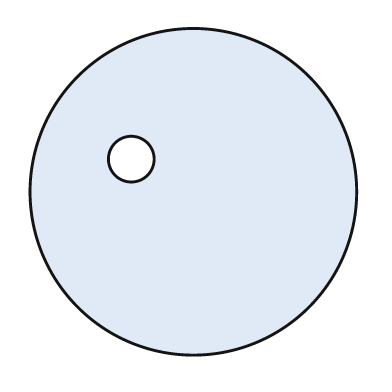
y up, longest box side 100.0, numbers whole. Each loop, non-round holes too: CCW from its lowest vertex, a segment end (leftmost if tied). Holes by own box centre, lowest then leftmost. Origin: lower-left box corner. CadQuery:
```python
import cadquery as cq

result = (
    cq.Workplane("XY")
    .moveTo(50.0, 50.0)
    .circle(50.0)
    .moveTo(31.0, 60.0)
    .circle(7.0)
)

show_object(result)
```